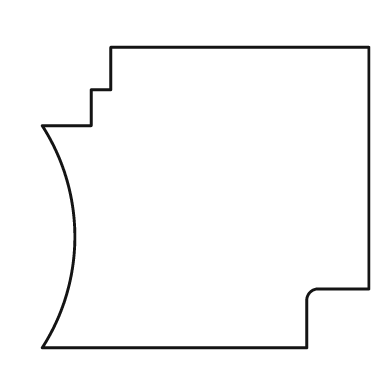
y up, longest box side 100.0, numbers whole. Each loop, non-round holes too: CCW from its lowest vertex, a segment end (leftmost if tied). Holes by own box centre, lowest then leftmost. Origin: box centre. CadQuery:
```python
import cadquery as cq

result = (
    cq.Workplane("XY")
    .moveTo(-50.0, -46.0)
    .lineTo(31.0, -46.0)
    .lineTo(31.0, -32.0)
    .threePointArc((32.0, -29.0), (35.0, -28.0))
    .lineTo(50.0, -28.0)
    .lineTo(50.0, 46.0)
    .lineTo(-29.0, 46.0)
    .lineTo(-29.0, 33.0)
    .lineTo(-35.0, 33.0)
    .lineTo(-35.0, 22.0)
    .lineTo(-50.0, 22.0)
    .threePointArc((-40.0, -12.0), (-50.0, -46.0))
    .close()
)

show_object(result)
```